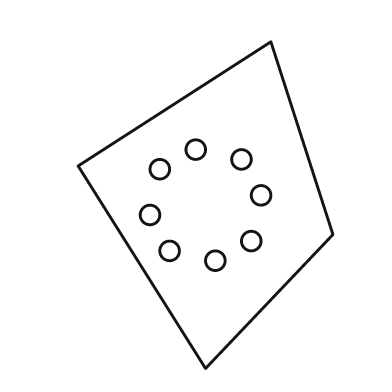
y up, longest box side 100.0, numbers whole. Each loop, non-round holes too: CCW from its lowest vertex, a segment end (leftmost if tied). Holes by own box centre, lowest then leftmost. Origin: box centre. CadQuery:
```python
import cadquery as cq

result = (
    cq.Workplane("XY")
    .moveTo(0.0, -50.0)
    .lineTo(39.0, -9.0)
    .lineTo(20.0, 50.0)
    .lineTo(-39.0, 12.0)
    .close()
    .moveTo(3.0, -17.0)
    .circle(3.0)
    .moveTo(-11.0, -14.0)
    .circle(3.0)
    .moveTo(14.0, -11.0)
    .circle(3.0)
    .moveTo(-17.0, -3.0)
    .circle(3.0)
    .moveTo(17.0, 3.0)
    .circle(3.0)
    .moveTo(-14.0, 11.0)
    .circle(3.0)
    .moveTo(11.0, 14.0)
    .circle(3.0)
    .moveTo(-3.0, 17.0)
    .circle(3.0)
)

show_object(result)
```